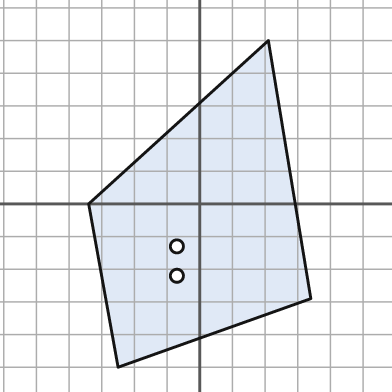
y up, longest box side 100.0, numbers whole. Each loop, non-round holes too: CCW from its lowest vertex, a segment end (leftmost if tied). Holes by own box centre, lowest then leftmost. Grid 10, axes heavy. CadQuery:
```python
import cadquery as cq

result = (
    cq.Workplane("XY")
    .moveTo(-25.0, -50.0)
    .lineTo(34.0, -29.0)
    .lineTo(21.0, 50.0)
    .lineTo(-34.0, 0.0)
    .close()
    .moveTo(-7.0, -22.0)
    .circle(2.0)
    .moveTo(-7.0, -13.0)
    .circle(2.0)
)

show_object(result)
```